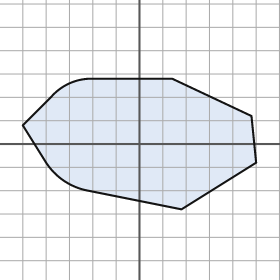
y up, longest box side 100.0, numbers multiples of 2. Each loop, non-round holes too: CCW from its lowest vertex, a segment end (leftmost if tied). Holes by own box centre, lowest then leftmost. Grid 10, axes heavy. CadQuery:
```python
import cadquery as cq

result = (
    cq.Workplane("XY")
    .moveTo(18.0, -28.0)
    .lineTo(50.0, -8.0)
    .lineTo(48.0, 12.0)
    .lineTo(14.0, 28.0)
    .lineTo(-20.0, 28.0)
    .threePointArc((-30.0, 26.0), (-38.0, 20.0))
    .lineTo(-50.0, 8.0)
    .lineTo(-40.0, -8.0)
    .threePointArc((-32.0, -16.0), (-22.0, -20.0))
    .close()
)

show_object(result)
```